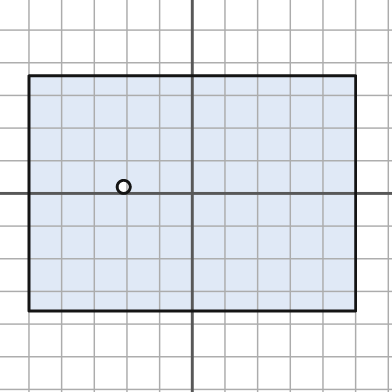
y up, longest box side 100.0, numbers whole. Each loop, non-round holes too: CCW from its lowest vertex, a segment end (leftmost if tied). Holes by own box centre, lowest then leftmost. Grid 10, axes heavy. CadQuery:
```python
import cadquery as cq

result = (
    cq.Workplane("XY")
    .moveTo(-50.0, -36.0)
    .lineTo(50.0, -36.0)
    .lineTo(50.0, 36.0)
    .lineTo(-50.0, 36.0)
    .close()
    .moveTo(-21.0, 2.0)
    .circle(2.0)
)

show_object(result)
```